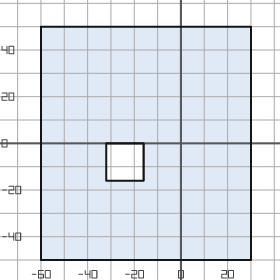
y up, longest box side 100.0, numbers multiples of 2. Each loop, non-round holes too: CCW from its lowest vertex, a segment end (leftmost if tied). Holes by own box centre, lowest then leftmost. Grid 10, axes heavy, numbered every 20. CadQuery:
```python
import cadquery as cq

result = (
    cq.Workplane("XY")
    .moveTo(-60.0, -50.0)
    .lineTo(30.0, -50.0)
    .lineTo(30.0, 50.0)
    .lineTo(-60.0, 50.0)
    .close()
    .moveTo(-32.0, -16.0)
    .lineTo(-16.0, -16.0)
    .lineTo(-16.0, 0.0)
    .lineTo(-32.0, 0.0)
    .close()
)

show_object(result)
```